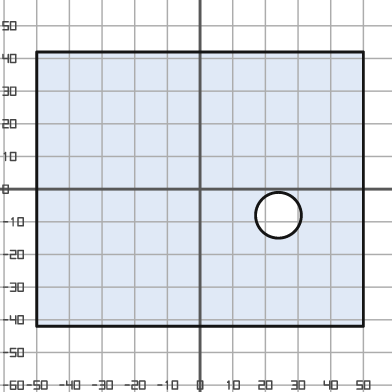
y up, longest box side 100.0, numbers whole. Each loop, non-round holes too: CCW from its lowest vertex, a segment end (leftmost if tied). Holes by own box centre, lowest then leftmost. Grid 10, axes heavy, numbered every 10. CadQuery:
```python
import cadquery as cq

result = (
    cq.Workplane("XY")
    .moveTo(-50.0, -42.0)
    .lineTo(50.0, -42.0)
    .lineTo(50.0, 42.0)
    .lineTo(-50.0, 42.0)
    .close()
    .moveTo(24.0, -8.0)
    .circle(7.0)
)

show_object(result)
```